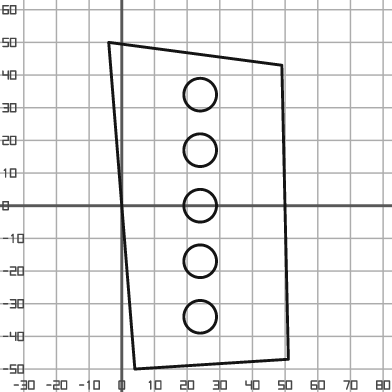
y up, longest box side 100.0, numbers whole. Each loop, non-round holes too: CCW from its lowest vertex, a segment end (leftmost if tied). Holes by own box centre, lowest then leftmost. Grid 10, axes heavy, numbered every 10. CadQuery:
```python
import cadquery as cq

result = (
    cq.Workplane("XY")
    .moveTo(4.0, -50.0)
    .lineTo(51.0, -47.0)
    .lineTo(49.0, 43.0)
    .lineTo(-4.0, 50.0)
    .close()
    .moveTo(24.0, -34.0)
    .circle(5.0)
    .moveTo(24.0, -17.0)
    .circle(5.0)
    .moveTo(24.0, 0.0)
    .circle(5.0)
    .moveTo(24.0, 17.0)
    .circle(5.0)
    .moveTo(24.0, 34.0)
    .circle(5.0)
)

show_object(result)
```